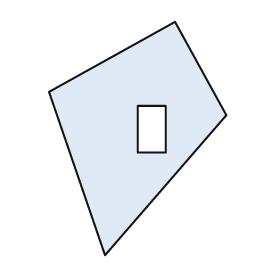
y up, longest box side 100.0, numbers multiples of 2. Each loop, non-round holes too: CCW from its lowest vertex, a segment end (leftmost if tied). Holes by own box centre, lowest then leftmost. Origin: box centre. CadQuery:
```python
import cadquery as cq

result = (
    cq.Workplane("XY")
    .moveTo(-14.0, -50.0)
    .lineTo(38.0, 10.0)
    .lineTo(16.0, 50.0)
    .lineTo(-38.0, 20.0)
    .close()
    .moveTo(0.0, -6.0)
    .lineTo(12.0, -6.0)
    .lineTo(12.0, 14.0)
    .lineTo(0.0, 14.0)
    .close()
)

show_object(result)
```